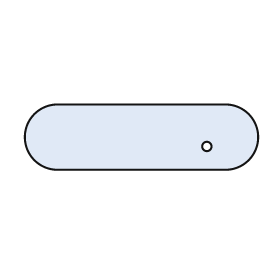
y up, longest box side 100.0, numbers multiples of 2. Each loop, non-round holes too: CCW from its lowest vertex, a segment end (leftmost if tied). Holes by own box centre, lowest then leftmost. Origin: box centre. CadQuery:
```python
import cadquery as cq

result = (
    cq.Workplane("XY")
    .moveTo(-36.0, -14.0)
    .lineTo(36.0, -14.0)
    .threePointArc((50.0, 0.0), (36.0, 14.0))
    .lineTo(-36.0, 14.0)
    .threePointArc((-50.0, 0.0), (-36.0, -14.0))
    .close()
    .moveTo(28.0, -4.0)
    .circle(2.0)
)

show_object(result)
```